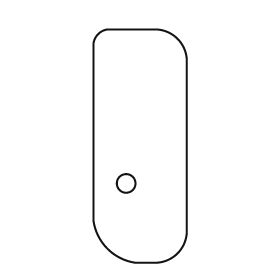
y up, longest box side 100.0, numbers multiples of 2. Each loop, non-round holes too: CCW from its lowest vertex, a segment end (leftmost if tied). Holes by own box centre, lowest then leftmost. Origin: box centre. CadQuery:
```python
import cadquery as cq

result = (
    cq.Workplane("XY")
    .moveTo(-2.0, -50.0)
    .lineTo(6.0, -50.0)
    .threePointArc((16.0, -46.0), (20.0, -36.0))
    .lineTo(20.0, 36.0)
    .threePointArc((16.0, 46.0), (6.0, 50.0))
    .lineTo(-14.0, 50.0)
    .threePointArc((-18.0, 48.0), (-20.0, 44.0))
    .lineTo(-20.0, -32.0)
    .threePointArc((-14.0, -44.0), (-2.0, -50.0))
    .close()
    .moveTo(-6.0, -16.0)
    .circle(4.0)
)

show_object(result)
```